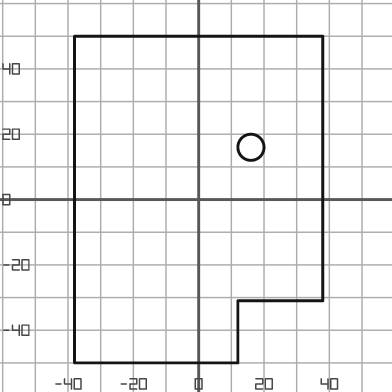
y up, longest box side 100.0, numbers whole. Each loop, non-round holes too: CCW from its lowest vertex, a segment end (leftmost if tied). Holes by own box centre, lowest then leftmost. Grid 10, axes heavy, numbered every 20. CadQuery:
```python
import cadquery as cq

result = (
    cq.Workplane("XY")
    .moveTo(-38.0, -50.0)
    .lineTo(12.0, -50.0)
    .lineTo(12.0, -31.0)
    .lineTo(38.0, -31.0)
    .lineTo(38.0, 50.0)
    .lineTo(-38.0, 50.0)
    .close()
    .moveTo(16.0, 16.0)
    .circle(4.0)
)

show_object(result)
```